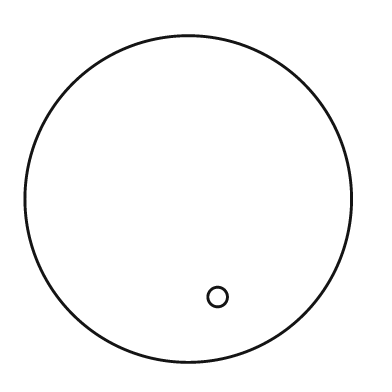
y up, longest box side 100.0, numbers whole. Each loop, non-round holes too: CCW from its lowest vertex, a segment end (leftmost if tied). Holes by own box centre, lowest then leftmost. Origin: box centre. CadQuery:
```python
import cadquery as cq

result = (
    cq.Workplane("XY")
    .moveTo(0.0, 0.0)
    .circle(50.0)
    .moveTo(9.0, -30.0)
    .circle(3.0)
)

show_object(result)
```